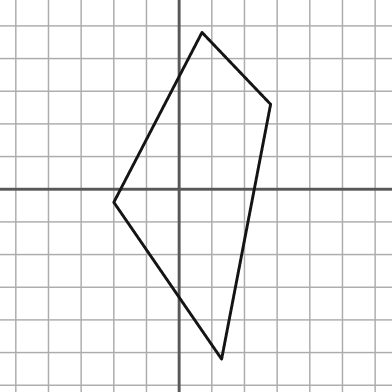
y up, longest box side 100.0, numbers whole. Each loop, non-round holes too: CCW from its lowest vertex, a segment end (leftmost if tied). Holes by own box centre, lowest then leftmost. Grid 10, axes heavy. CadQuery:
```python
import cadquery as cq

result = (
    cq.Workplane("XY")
    .moveTo(13.0, -52.0)
    .lineTo(28.0, 26.0)
    .lineTo(7.0, 48.0)
    .lineTo(-20.0, -4.0)
    .close()
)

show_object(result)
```